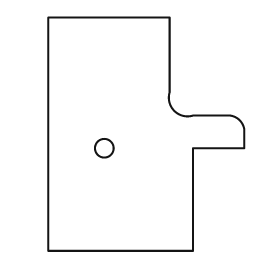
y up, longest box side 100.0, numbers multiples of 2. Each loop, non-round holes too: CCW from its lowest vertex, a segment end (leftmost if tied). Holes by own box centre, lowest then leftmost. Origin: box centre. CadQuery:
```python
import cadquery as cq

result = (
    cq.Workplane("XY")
    .moveTo(-42.0, -50.0)
    .lineTo(20.0, -50.0)
    .lineTo(20.0, -6.0)
    .lineTo(42.0, -6.0)
    .lineTo(42.0, 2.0)
    .threePointArc((40.0, 6.0), (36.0, 8.0))
    .lineTo(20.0, 8.0)
    .threePointArc((12.0, 10.0), (10.0, 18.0))
    .lineTo(10.0, 50.0)
    .lineTo(-42.0, 50.0)
    .close()
    .moveTo(-18.0, -6.0)
    .circle(4.0)
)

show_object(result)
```